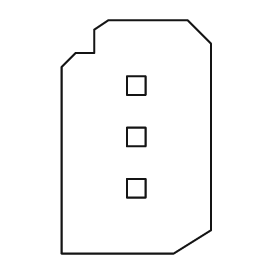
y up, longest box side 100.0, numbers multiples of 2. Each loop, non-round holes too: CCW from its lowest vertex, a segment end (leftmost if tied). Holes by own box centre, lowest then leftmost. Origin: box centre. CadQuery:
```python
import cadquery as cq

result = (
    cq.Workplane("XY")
    .moveTo(-32.0, -50.0)
    .lineTo(16.0, -50.0)
    .lineTo(32.0, -40.0)
    .lineTo(32.0, 40.0)
    .lineTo(22.0, 50.0)
    .lineTo(-12.0, 50.0)
    .lineTo(-18.0, 46.0)
    .lineTo(-18.0, 36.0)
    .lineTo(-26.0, 36.0)
    .lineTo(-32.0, 30.0)
    .close()
    .moveTo(-4.0, -26.0)
    .lineTo(4.0, -26.0)
    .lineTo(4.0, -18.0)
    .lineTo(-4.0, -18.0)
    .close()
    .moveTo(-4.0, -4.0)
    .lineTo(4.0, -4.0)
    .lineTo(4.0, 4.0)
    .lineTo(-4.0, 4.0)
    .close()
    .moveTo(-4.0, 18.0)
    .lineTo(4.0, 18.0)
    .lineTo(4.0, 26.0)
    .lineTo(-4.0, 26.0)
    .close()
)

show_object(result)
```